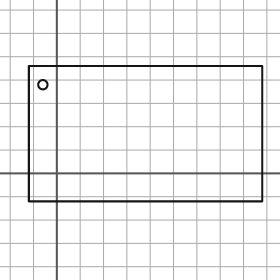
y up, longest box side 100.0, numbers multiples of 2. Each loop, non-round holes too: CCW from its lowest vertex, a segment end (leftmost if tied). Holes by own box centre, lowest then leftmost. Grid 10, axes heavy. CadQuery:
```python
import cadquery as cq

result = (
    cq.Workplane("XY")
    .moveTo(-12.0, -12.0)
    .lineTo(88.0, -12.0)
    .lineTo(88.0, 46.0)
    .lineTo(-12.0, 46.0)
    .close()
    .moveTo(-6.0, 38.0)
    .circle(2.0)
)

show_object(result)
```